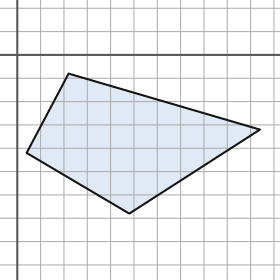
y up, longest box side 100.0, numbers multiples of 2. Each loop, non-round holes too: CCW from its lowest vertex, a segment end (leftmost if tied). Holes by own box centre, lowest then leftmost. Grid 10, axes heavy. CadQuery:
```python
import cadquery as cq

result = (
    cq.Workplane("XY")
    .moveTo(48.0, -68.0)
    .lineTo(104.0, -32.0)
    .lineTo(22.0, -8.0)
    .lineTo(4.0, -42.0)
    .close()
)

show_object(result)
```